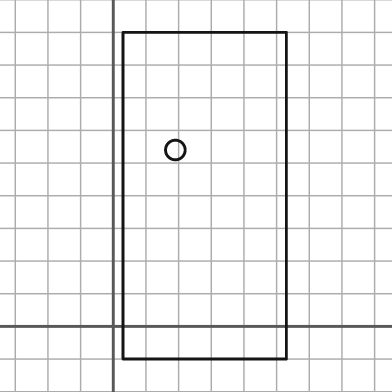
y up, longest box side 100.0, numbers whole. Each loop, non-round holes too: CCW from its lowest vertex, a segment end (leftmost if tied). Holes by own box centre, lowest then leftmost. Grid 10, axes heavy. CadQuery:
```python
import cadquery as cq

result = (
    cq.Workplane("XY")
    .moveTo(3.0, -10.0)
    .lineTo(53.0, -10.0)
    .lineTo(53.0, 90.0)
    .lineTo(3.0, 90.0)
    .close()
    .moveTo(19.0, 54.0)
    .circle(3.0)
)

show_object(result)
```